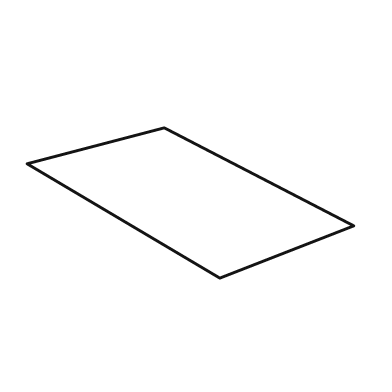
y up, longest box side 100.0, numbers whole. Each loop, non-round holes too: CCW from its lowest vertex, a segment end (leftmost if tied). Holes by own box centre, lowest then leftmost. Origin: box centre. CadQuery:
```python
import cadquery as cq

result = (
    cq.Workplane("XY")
    .moveTo(9.0, -23.0)
    .lineTo(50.0, -7.0)
    .lineTo(-8.0, 23.0)
    .lineTo(-50.0, 12.0)
    .close()
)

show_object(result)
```